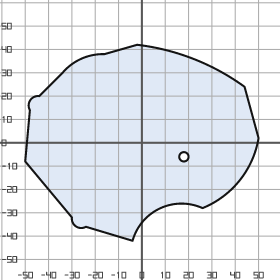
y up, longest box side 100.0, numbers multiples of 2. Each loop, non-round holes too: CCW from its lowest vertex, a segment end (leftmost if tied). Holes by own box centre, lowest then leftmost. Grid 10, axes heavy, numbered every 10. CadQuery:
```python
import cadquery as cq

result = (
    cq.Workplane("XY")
    .moveTo(-4.0, -42.0)
    .threePointArc((8.0, -28.0), (26.0, -28.0))
    .threePointArc((42.0, -16.0), (50.0, 2.0))
    .lineTo(44.0, 24.0)
    .threePointArc((22.0, 36.0), (-2.0, 42.0))
    .lineTo(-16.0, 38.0)
    .threePointArc((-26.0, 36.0), (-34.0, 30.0))
    .lineTo(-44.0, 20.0)
    .threePointArc((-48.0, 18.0), (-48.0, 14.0))
    .lineTo(-50.0, -8.0)
    .lineTo(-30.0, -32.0)
    .threePointArc((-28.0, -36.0), (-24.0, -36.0))
    .close()
    .moveTo(18.0, -6.0)
    .circle(2.0)
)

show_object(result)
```